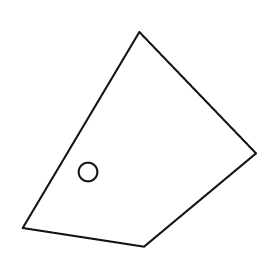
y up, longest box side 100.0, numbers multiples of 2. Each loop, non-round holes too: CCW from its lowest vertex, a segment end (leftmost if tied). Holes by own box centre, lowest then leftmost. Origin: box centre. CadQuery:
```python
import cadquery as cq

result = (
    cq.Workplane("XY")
    .moveTo(2.0, -46.0)
    .lineTo(50.0, -6.0)
    .lineTo(0.0, 46.0)
    .lineTo(-50.0, -38.0)
    .close()
    .moveTo(-22.0, -14.0)
    .circle(4.0)
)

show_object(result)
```